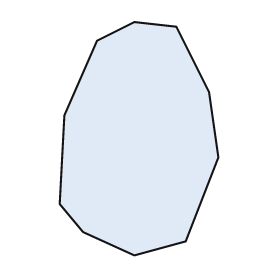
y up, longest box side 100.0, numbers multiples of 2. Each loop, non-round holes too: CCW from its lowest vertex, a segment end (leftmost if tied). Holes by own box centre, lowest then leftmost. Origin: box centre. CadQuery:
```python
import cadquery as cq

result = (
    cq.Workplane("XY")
    .moveTo(-2.0, -50.0)
    .lineTo(20.0, -44.0)
    .lineTo(34.0, -8.0)
    .lineTo(30.0, 20.0)
    .lineTo(16.0, 48.0)
    .lineTo(-2.0, 50.0)
    .lineTo(-18.0, 42.0)
    .lineTo(-32.0, 10.0)
    .lineTo(-34.0, -28.0)
    .lineTo(-24.0, -40.0)
    .close()
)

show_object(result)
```